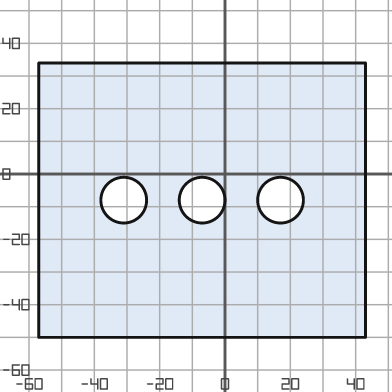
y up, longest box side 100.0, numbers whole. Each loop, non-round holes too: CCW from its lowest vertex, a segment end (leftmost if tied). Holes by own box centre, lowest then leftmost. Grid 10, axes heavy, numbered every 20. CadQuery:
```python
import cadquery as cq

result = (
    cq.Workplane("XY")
    .moveTo(-57.0, -50.0)
    .lineTo(43.0, -50.0)
    .lineTo(43.0, 34.0)
    .lineTo(-57.0, 34.0)
    .close()
    .moveTo(-31.0, -8.0)
    .circle(7.0)
    .moveTo(-7.0, -8.0)
    .circle(7.0)
    .moveTo(17.0, -8.0)
    .circle(7.0)
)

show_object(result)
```